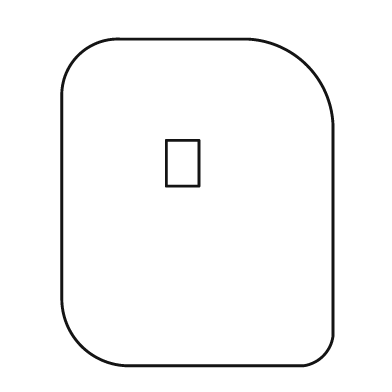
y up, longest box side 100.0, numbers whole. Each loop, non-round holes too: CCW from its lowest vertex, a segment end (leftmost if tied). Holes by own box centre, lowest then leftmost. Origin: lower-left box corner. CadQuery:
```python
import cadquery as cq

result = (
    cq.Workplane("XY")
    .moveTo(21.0, 0.0)
    .lineTo(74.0, 0.0)
    .threePointArc((80.0, 3.0), (83.0, 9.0))
    .lineTo(83.0, 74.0)
    .threePointArc((75.0, 92.0), (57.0, 100.0))
    .lineTo(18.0, 100.0)
    .threePointArc((5.0, 95.0), (0.0, 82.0))
    .lineTo(0.0, 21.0)
    .threePointArc((6.0, 6.0), (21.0, 0.0))
    .close()
    .moveTo(32.0, 55.0)
    .lineTo(42.0, 55.0)
    .lineTo(42.0, 69.0)
    .lineTo(32.0, 69.0)
    .close()
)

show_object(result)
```